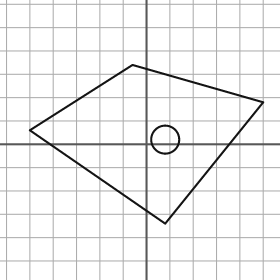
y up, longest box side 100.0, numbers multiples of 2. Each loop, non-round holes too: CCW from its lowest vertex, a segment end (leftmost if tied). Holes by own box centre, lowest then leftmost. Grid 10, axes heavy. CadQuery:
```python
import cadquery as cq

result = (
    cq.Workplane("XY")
    .moveTo(8.0, -34.0)
    .lineTo(50.0, 18.0)
    .lineTo(-6.0, 34.0)
    .lineTo(-50.0, 6.0)
    .close()
    .moveTo(8.0, 2.0)
    .circle(6.0)
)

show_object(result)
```